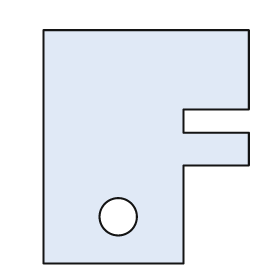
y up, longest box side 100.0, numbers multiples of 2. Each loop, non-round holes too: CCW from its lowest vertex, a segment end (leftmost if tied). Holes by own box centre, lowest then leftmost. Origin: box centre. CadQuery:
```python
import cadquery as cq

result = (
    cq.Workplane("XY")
    .moveTo(-44.0, -50.0)
    .lineTo(16.0, -50.0)
    .lineTo(16.0, -8.0)
    .lineTo(44.0, -8.0)
    .lineTo(44.0, 6.0)
    .lineTo(16.0, 6.0)
    .lineTo(16.0, 16.0)
    .lineTo(44.0, 16.0)
    .lineTo(44.0, 50.0)
    .lineTo(-44.0, 50.0)
    .close()
    .moveTo(-12.0, -30.0)
    .circle(8.0)
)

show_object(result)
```